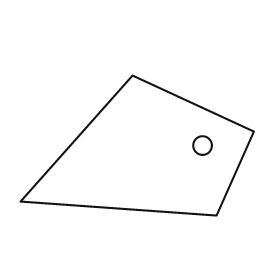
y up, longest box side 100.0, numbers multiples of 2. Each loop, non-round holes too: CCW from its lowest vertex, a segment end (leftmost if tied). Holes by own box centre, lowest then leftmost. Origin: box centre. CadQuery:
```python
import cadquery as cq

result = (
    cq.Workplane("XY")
    .moveTo(34.0, -30.0)
    .lineTo(50.0, 6.0)
    .lineTo(-2.0, 30.0)
    .lineTo(-50.0, -24.0)
    .close()
    .moveTo(28.0, 0.0)
    .circle(4.0)
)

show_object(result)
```